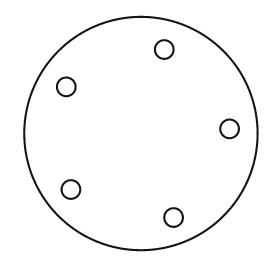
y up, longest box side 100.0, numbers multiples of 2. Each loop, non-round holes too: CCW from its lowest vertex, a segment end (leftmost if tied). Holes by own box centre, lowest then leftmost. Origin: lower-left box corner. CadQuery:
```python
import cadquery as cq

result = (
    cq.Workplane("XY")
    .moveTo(50.0, 50.0)
    .circle(50.0)
    .moveTo(64.0, 14.0)
    .circle(4.0)
    .moveTo(20.0, 26.0)
    .circle(4.0)
    .moveTo(88.0, 52.0)
    .circle(4.0)
    .moveTo(18.0, 70.0)
    .circle(4.0)
    .moveTo(60.0, 86.0)
    .circle(4.0)
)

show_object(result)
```